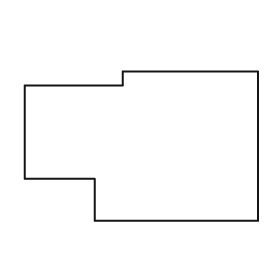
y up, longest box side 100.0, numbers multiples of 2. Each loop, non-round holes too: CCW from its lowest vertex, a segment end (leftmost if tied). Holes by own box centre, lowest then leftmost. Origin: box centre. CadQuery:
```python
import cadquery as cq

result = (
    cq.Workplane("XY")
    .moveTo(-20.0, -32.0)
    .lineTo(50.0, -32.0)
    .lineTo(50.0, 32.0)
    .lineTo(-8.0, 32.0)
    .lineTo(-8.0, 26.0)
    .lineTo(-50.0, 26.0)
    .lineTo(-50.0, -14.0)
    .lineTo(-20.0, -14.0)
    .close()
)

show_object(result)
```